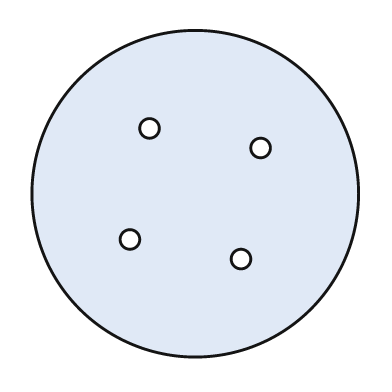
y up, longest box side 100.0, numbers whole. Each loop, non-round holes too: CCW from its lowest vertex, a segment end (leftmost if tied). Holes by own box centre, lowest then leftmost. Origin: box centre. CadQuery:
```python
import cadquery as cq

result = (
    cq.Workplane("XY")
    .moveTo(0.0, 0.0)
    .circle(50.0)
    .moveTo(14.0, -20.0)
    .circle(3.0)
    .moveTo(-20.0, -14.0)
    .circle(3.0)
    .moveTo(20.0, 14.0)
    .circle(3.0)
    .moveTo(-14.0, 20.0)
    .circle(3.0)
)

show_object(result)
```